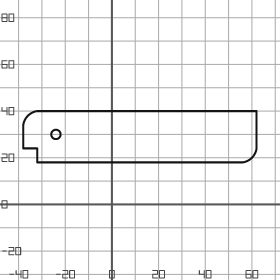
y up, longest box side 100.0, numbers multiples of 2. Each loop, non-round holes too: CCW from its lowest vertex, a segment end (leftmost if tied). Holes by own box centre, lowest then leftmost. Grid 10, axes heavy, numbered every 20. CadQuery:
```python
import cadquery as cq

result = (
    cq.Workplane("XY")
    .moveTo(-32.0, 18.0)
    .lineTo(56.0, 18.0)
    .threePointArc((60.0, 20.0), (62.0, 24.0))
    .lineTo(62.0, 40.0)
    .lineTo(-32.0, 40.0)
    .threePointArc((-36.0, 38.0), (-38.0, 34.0))
    .lineTo(-38.0, 24.0)
    .lineTo(-32.0, 24.0)
    .close()
    .moveTo(-24.0, 30.0)
    .circle(2.0)
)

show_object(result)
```